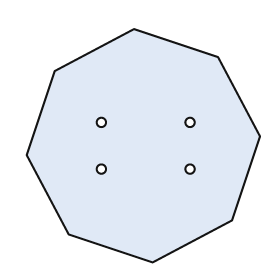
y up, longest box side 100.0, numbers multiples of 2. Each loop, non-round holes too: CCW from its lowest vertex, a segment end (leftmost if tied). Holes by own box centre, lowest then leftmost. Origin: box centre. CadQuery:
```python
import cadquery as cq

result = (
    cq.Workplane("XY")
    .moveTo(4.0, -50.0)
    .lineTo(38.0, -32.0)
    .lineTo(50.0, 4.0)
    .lineTo(32.0, 38.0)
    .lineTo(-4.0, 50.0)
    .lineTo(-38.0, 32.0)
    .lineTo(-50.0, -4.0)
    .lineTo(-32.0, -38.0)
    .close()
    .moveTo(-18.0, -10.0)
    .circle(2.0)
    .moveTo(20.0, -10.0)
    .circle(2.0)
    .moveTo(-18.0, 10.0)
    .circle(2.0)
    .moveTo(20.0, 10.0)
    .circle(2.0)
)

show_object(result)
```